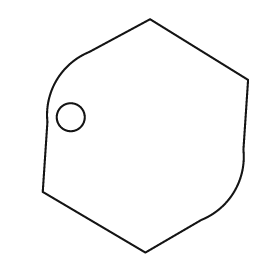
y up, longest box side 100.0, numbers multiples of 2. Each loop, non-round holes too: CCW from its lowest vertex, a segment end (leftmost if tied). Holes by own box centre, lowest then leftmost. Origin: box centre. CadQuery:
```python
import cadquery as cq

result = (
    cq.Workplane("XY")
    .moveTo(0.0, -50.0)
    .lineTo(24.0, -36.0)
    .threePointArc((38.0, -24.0), (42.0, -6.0))
    .lineTo(44.0, 24.0)
    .lineTo(2.0, 50.0)
    .lineTo(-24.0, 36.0)
    .threePointArc((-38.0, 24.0), (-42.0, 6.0))
    .lineTo(-44.0, -24.0)
    .close()
    .moveTo(-32.0, 8.0)
    .circle(6.0)
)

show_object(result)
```